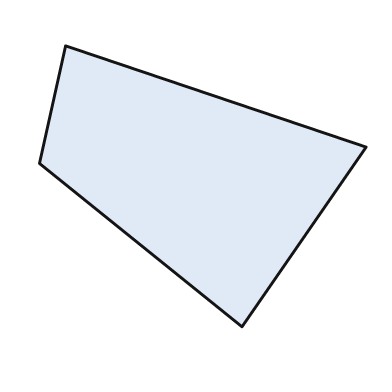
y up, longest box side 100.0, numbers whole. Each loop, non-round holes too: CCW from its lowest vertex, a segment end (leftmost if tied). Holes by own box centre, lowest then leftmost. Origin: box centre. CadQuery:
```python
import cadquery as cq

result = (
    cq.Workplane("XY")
    .moveTo(12.0, -43.0)
    .lineTo(50.0, 12.0)
    .lineTo(-42.0, 43.0)
    .lineTo(-50.0, 7.0)
    .close()
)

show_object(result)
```